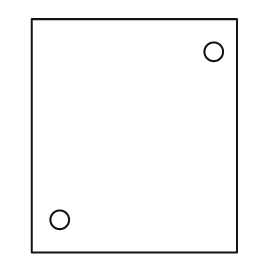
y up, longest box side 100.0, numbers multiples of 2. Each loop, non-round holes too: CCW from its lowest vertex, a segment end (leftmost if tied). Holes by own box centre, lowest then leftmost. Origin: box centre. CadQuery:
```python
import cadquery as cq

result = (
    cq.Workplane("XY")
    .moveTo(-44.0, -50.0)
    .lineTo(44.0, -50.0)
    .lineTo(44.0, 50.0)
    .lineTo(-44.0, 50.0)
    .close()
    .moveTo(-32.0, -36.0)
    .circle(4.0)
    .moveTo(34.0, 36.0)
    .circle(4.0)
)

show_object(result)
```